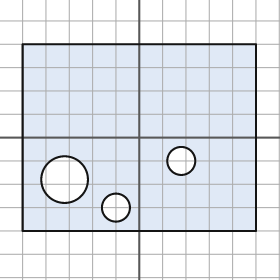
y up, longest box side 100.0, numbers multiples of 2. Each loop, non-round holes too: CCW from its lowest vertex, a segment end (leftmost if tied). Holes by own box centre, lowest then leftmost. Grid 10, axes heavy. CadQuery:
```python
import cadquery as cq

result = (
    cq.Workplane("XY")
    .moveTo(-50.0, -40.0)
    .lineTo(50.0, -40.0)
    .lineTo(50.0, 40.0)
    .lineTo(-50.0, 40.0)
    .close()
    .moveTo(-10.0, -30.0)
    .circle(6.0)
    .moveTo(-32.0, -18.0)
    .circle(10.0)
    .moveTo(18.0, -10.0)
    .circle(6.0)
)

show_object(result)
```